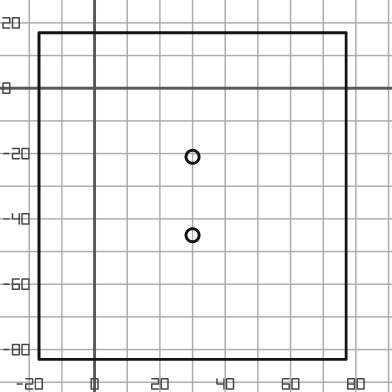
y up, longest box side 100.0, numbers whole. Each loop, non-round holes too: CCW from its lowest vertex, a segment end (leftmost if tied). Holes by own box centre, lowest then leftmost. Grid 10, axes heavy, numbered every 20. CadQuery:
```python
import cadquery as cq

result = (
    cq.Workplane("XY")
    .moveTo(-17.0, -83.0)
    .lineTo(77.0, -83.0)
    .lineTo(77.0, 17.0)
    .lineTo(-17.0, 17.0)
    .close()
    .moveTo(30.0, -45.0)
    .circle(2.0)
    .moveTo(30.0, -21.0)
    .circle(2.0)
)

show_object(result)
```